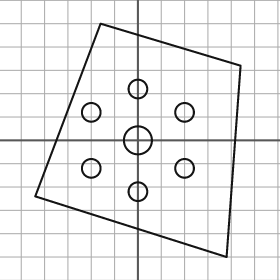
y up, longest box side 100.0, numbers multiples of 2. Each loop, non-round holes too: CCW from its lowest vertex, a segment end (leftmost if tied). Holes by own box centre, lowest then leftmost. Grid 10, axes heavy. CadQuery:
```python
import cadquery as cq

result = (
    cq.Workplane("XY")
    .moveTo(38.0, -50.0)
    .lineTo(44.0, 32.0)
    .lineTo(-16.0, 50.0)
    .lineTo(-44.0, -24.0)
    .close()
    .moveTo(0.0, -22.0)
    .circle(4.0)
    .moveTo(-20.0, -12.0)
    .circle(4.0)
    .moveTo(20.0, -12.0)
    .circle(4.0)
    .moveTo(0.0, 0.0)
    .circle(6.0)
    .moveTo(-20.0, 12.0)
    .circle(4.0)
    .moveTo(20.0, 12.0)
    .circle(4.0)
    .moveTo(0.0, 22.0)
    .circle(4.0)
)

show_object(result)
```